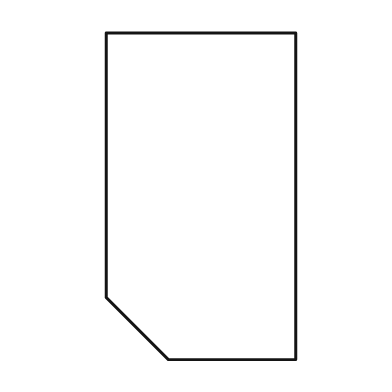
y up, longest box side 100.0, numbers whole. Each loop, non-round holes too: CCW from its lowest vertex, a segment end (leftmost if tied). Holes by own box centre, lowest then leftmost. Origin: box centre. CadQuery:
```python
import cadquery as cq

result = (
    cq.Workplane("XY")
    .moveTo(-10.0, -50.0)
    .lineTo(29.0, -50.0)
    .lineTo(29.0, 50.0)
    .lineTo(-29.0, 50.0)
    .lineTo(-29.0, -31.0)
    .close()
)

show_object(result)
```